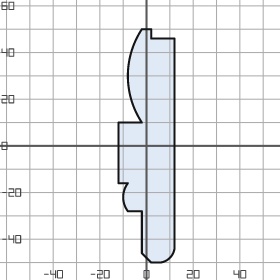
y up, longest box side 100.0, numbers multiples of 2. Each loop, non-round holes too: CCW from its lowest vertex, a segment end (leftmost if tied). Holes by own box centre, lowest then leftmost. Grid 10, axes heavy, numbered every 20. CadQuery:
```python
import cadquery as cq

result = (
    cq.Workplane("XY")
    .moveTo(2.0, -50.0)
    .lineTo(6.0, -50.0)
    .threePointArc((10.0, -48.0), (12.0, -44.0))
    .lineTo(12.0, 46.0)
    .lineTo(2.0, 46.0)
    .lineTo(2.0, 50.0)
    .lineTo(-2.0, 50.0)
    .threePointArc((-8.0, 30.0), (-2.0, 10.0))
    .lineTo(-12.0, 10.0)
    .lineTo(-12.0, -16.0)
    .lineTo(-8.0, -16.0)
    .threePointArc((-10.0, -22.0), (-8.0, -28.0))
    .lineTo(-2.0, -28.0)
    .lineTo(-2.0, -46.0)
    .close()
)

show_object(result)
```